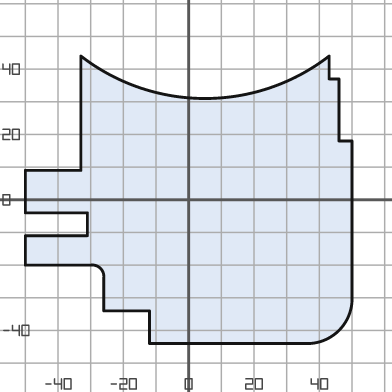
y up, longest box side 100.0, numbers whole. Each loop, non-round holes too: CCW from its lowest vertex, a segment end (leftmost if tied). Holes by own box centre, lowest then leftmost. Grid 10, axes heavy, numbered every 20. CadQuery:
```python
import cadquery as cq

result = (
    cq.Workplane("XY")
    .moveTo(-12.0, -44.0)
    .lineTo(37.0, -44.0)
    .threePointArc((46.0, -40.0), (50.0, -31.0))
    .lineTo(50.0, 18.0)
    .lineTo(46.0, 18.0)
    .lineTo(46.0, 37.0)
    .lineTo(43.0, 37.0)
    .lineTo(43.0, 44.0)
    .threePointArc((5.0, 31.0), (-33.0, 44.0))
    .lineTo(-33.0, 9.0)
    .lineTo(-50.0, 9.0)
    .lineTo(-50.0, -4.0)
    .lineTo(-31.0, -4.0)
    .lineTo(-31.0, -11.0)
    .lineTo(-50.0, -11.0)
    .lineTo(-50.0, -20.0)
    .lineTo(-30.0, -20.0)
    .threePointArc((-27.0, -21.0), (-26.0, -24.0))
    .lineTo(-26.0, -34.0)
    .lineTo(-12.0, -34.0)
    .close()
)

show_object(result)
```